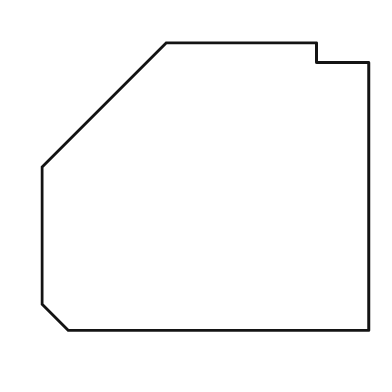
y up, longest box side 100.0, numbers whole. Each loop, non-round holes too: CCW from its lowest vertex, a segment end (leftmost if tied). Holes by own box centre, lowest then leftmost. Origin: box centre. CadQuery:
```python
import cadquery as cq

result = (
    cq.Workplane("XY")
    .moveTo(-42.0, -44.0)
    .lineTo(50.0, -44.0)
    .lineTo(50.0, 38.0)
    .lineTo(34.0, 38.0)
    .lineTo(34.0, 44.0)
    .lineTo(-12.0, 44.0)
    .lineTo(-50.0, 6.0)
    .lineTo(-50.0, -36.0)
    .close()
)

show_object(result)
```